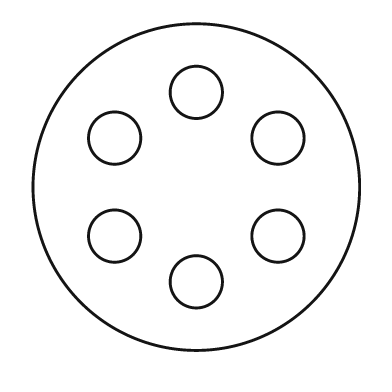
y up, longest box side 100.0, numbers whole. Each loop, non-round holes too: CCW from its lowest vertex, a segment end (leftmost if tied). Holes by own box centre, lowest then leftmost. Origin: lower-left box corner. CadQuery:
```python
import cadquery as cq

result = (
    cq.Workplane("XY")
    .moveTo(50.0, 50.0)
    .circle(50.0)
    .moveTo(50.0, 21.0)
    .circle(8.0)
    .moveTo(25.0, 35.0)
    .circle(8.0)
    .moveTo(75.0, 35.0)
    .circle(8.0)
    .moveTo(25.0, 65.0)
    .circle(8.0)
    .moveTo(75.0, 65.0)
    .circle(8.0)
    .moveTo(50.0, 79.0)
    .circle(8.0)
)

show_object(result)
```